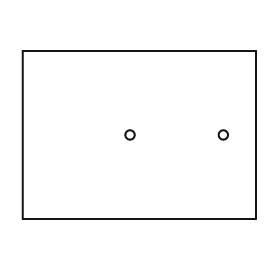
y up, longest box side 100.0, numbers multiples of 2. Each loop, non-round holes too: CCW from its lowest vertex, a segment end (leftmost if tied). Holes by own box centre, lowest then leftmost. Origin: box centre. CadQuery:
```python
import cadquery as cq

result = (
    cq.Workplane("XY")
    .moveTo(-50.0, -36.0)
    .lineTo(50.0, -36.0)
    .lineTo(50.0, 36.0)
    .lineTo(-50.0, 36.0)
    .close()
    .moveTo(-4.0, 0.0)
    .circle(2.0)
    .moveTo(36.0, 0.0)
    .circle(2.0)
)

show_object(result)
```